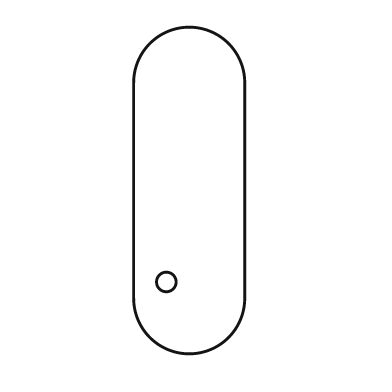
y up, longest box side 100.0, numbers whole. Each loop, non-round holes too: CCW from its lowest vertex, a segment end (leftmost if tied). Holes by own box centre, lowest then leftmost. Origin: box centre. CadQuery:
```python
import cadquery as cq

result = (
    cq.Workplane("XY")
    .moveTo(-17.0, -33.0)
    .threePointArc((0.0, -50.0), (17.0, -33.0))
    .lineTo(17.0, 33.0)
    .threePointArc((0.0, 50.0), (-17.0, 33.0))
    .close()
    .moveTo(-7.0, -28.0)
    .circle(3.0)
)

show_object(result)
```